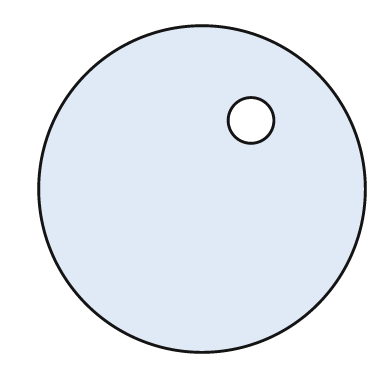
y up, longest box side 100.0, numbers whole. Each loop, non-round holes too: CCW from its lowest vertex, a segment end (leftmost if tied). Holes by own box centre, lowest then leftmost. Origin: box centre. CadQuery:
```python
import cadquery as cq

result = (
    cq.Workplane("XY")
    .moveTo(0.0, 0.0)
    .circle(50.0)
    .moveTo(15.0, 21.0)
    .circle(7.0)
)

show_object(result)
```